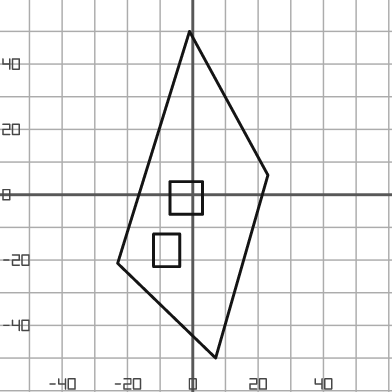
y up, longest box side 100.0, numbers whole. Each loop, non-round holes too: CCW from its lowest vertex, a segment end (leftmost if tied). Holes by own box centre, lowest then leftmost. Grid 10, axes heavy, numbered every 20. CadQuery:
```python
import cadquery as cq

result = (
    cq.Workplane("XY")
    .moveTo(7.0, -50.0)
    .lineTo(23.0, 6.0)
    .lineTo(-1.0, 50.0)
    .lineTo(-23.0, -21.0)
    .close()
    .moveTo(-12.0, -22.0)
    .lineTo(-4.0, -22.0)
    .lineTo(-4.0, -12.0)
    .lineTo(-12.0, -12.0)
    .close()
    .moveTo(-7.0, -6.0)
    .lineTo(3.0, -6.0)
    .lineTo(3.0, 4.0)
    .lineTo(-7.0, 4.0)
    .close()
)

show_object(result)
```